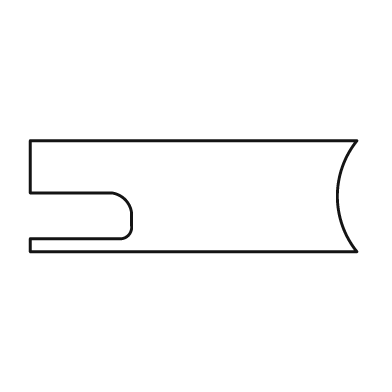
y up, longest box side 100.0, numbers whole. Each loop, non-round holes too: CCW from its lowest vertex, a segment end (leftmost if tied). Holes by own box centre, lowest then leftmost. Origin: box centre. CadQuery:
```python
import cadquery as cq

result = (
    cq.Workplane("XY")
    .moveTo(-50.0, -17.0)
    .lineTo(50.0, -17.0)
    .threePointArc((44.0, 0.0), (50.0, 17.0))
    .lineTo(-50.0, 17.0)
    .lineTo(-50.0, 1.0)
    .lineTo(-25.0, 1.0)
    .threePointArc((-21.0, -1.0), (-19.0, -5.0))
    .lineTo(-19.0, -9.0)
    .threePointArc((-20.0, -12.0), (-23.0, -13.0))
    .lineTo(-50.0, -13.0)
    .close()
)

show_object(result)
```